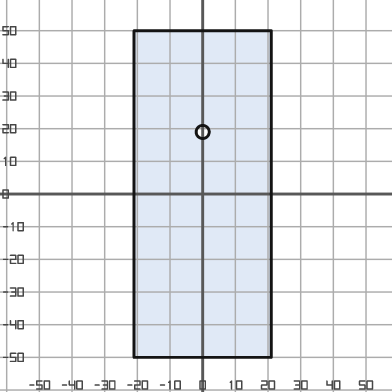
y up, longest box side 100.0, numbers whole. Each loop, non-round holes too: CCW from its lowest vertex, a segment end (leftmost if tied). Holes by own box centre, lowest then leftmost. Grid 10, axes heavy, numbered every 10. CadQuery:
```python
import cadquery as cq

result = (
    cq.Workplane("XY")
    .moveTo(-21.0, -50.0)
    .lineTo(21.0, -50.0)
    .lineTo(21.0, 50.0)
    .lineTo(-21.0, 50.0)
    .close()
    .moveTo(0.0, 19.0)
    .circle(2.0)
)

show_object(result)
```